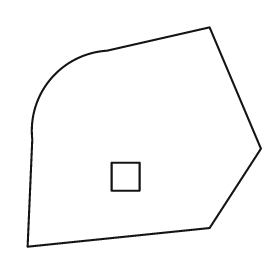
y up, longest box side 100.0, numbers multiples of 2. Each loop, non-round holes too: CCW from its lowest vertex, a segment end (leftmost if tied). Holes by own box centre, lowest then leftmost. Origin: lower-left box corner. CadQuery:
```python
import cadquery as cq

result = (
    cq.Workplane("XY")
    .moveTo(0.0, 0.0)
    .lineTo(78.0, 8.0)
    .lineTo(100.0, 42.0)
    .lineTo(78.0, 94.0)
    .lineTo(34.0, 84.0)
    .threePointArc((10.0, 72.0), (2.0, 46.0))
    .close()
    .moveTo(36.0, 24.0)
    .lineTo(48.0, 24.0)
    .lineTo(48.0, 36.0)
    .lineTo(36.0, 36.0)
    .close()
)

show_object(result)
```